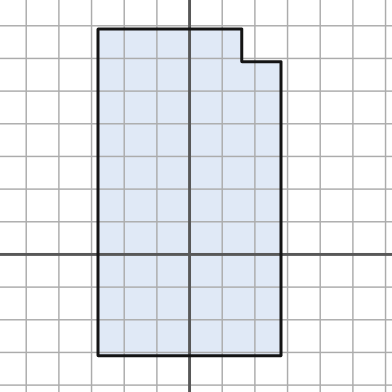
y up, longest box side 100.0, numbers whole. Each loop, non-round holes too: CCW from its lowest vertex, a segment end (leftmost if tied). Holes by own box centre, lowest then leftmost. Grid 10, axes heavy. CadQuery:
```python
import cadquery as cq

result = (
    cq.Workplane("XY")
    .moveTo(-28.0, -31.0)
    .lineTo(28.0, -31.0)
    .lineTo(28.0, 59.0)
    .lineTo(16.0, 59.0)
    .lineTo(16.0, 69.0)
    .lineTo(-28.0, 69.0)
    .close()
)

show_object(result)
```